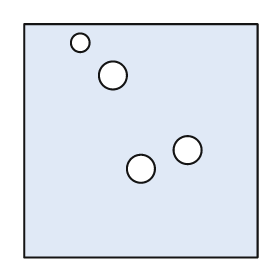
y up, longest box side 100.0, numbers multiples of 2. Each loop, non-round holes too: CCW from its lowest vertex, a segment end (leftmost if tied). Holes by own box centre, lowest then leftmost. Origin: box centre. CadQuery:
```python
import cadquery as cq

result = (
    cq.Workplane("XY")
    .moveTo(-50.0, -50.0)
    .lineTo(50.0, -50.0)
    .lineTo(50.0, 50.0)
    .lineTo(-50.0, 50.0)
    .close()
    .moveTo(0.0, -12.0)
    .circle(6.0)
    .moveTo(20.0, -4.0)
    .circle(6.0)
    .moveTo(-12.0, 28.0)
    .circle(6.0)
    .moveTo(-26.0, 42.0)
    .circle(4.0)
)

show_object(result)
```